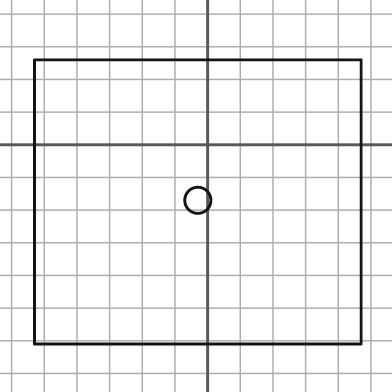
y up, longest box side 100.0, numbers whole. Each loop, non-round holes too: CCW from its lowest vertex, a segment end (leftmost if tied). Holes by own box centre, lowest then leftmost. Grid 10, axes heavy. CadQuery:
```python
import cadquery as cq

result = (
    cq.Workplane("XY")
    .moveTo(-53.0, -61.0)
    .lineTo(47.0, -61.0)
    .lineTo(47.0, 26.0)
    .lineTo(-53.0, 26.0)
    .close()
    .moveTo(-3.0, -17.0)
    .circle(4.0)
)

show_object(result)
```